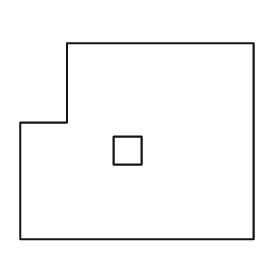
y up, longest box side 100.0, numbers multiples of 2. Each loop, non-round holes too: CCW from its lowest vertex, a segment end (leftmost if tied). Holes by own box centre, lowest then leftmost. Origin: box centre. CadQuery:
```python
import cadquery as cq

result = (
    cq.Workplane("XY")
    .moveTo(-50.0, -42.0)
    .lineTo(50.0, -42.0)
    .lineTo(50.0, 42.0)
    .lineTo(-30.0, 42.0)
    .lineTo(-30.0, 8.0)
    .lineTo(-50.0, 8.0)
    .close()
    .moveTo(-10.0, -10.0)
    .lineTo(2.0, -10.0)
    .lineTo(2.0, 2.0)
    .lineTo(-10.0, 2.0)
    .close()
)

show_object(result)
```